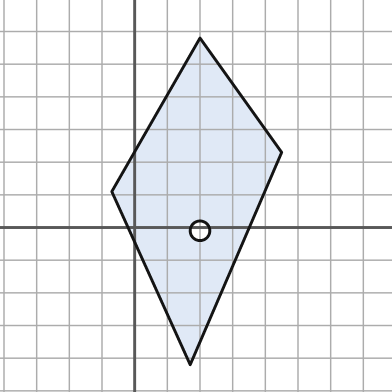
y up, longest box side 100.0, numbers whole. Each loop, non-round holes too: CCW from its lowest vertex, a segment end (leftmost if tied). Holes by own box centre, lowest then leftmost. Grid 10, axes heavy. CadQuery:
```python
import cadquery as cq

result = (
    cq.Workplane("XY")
    .moveTo(17.0, -42.0)
    .lineTo(45.0, 23.0)
    .lineTo(20.0, 58.0)
    .lineTo(-7.0, 11.0)
    .close()
    .moveTo(20.0, -1.0)
    .circle(3.0)
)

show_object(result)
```